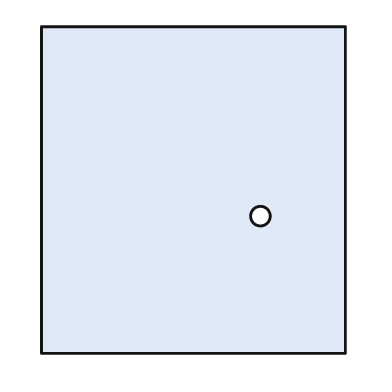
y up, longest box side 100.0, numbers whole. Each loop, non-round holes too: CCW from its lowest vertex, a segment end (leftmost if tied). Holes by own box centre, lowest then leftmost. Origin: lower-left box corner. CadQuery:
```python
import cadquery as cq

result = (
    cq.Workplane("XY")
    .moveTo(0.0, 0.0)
    .lineTo(93.0, 0.0)
    .lineTo(93.0, 100.0)
    .lineTo(0.0, 100.0)
    .close()
    .moveTo(67.0, 42.0)
    .circle(3.0)
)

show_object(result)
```